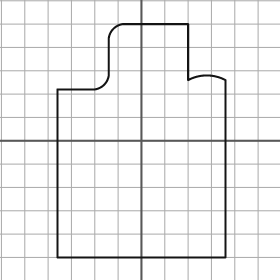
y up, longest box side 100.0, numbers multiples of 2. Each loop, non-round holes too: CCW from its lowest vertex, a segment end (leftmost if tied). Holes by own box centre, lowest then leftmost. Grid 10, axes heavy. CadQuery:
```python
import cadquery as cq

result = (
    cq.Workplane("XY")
    .moveTo(-36.0, -50.0)
    .lineTo(36.0, -50.0)
    .lineTo(36.0, 26.0)
    .threePointArc((28.0, 28.0), (20.0, 26.0))
    .lineTo(20.0, 50.0)
    .lineTo(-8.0, 50.0)
    .threePointArc((-12.0, 48.0), (-14.0, 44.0))
    .lineTo(-14.0, 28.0)
    .threePointArc((-16.0, 24.0), (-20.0, 22.0))
    .lineTo(-36.0, 22.0)
    .close()
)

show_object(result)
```